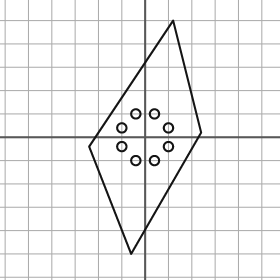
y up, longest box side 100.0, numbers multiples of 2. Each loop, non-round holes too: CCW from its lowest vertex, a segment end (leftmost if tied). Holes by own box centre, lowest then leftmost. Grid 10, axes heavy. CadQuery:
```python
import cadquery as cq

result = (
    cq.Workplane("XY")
    .moveTo(-6.0, -50.0)
    .lineTo(24.0, 2.0)
    .lineTo(12.0, 50.0)
    .lineTo(-24.0, -4.0)
    .close()
    .moveTo(-4.0, -10.0)
    .circle(2.0)
    .moveTo(4.0, -10.0)
    .circle(2.0)
    .moveTo(-10.0, -4.0)
    .circle(2.0)
    .moveTo(10.0, -4.0)
    .circle(2.0)
    .moveTo(-10.0, 4.0)
    .circle(2.0)
    .moveTo(10.0, 4.0)
    .circle(2.0)
    .moveTo(-4.0, 10.0)
    .circle(2.0)
    .moveTo(4.0, 10.0)
    .circle(2.0)
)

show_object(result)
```